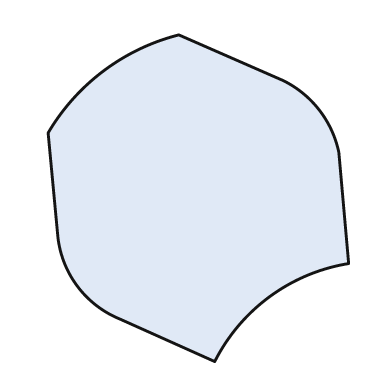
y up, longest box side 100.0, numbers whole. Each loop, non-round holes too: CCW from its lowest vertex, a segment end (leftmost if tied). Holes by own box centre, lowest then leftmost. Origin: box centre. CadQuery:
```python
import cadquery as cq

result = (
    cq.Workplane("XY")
    .moveTo(5.0, -50.0)
    .threePointArc((22.0, -30.0), (46.0, -20.0))
    .lineTo(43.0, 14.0)
    .threePointArc((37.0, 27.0), (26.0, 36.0))
    .lineTo(-6.0, 50.0)
    .threePointArc((-29.0, 39.0), (-46.0, 20.0))
    .lineTo(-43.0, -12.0)
    .threePointArc((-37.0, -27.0), (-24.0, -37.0))
    .close()
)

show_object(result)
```